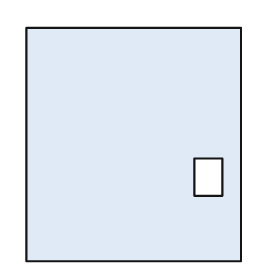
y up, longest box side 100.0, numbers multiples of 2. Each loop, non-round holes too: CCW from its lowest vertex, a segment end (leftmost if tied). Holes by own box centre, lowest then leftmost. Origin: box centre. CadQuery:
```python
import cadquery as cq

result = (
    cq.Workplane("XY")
    .moveTo(-46.0, -50.0)
    .lineTo(46.0, -50.0)
    .lineTo(46.0, 50.0)
    .lineTo(-46.0, 50.0)
    .close()
    .moveTo(26.0, -22.0)
    .lineTo(38.0, -22.0)
    .lineTo(38.0, -6.0)
    .lineTo(26.0, -6.0)
    .close()
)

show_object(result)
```